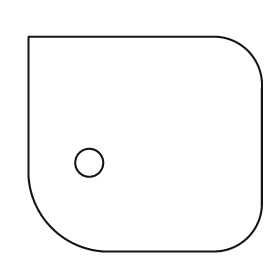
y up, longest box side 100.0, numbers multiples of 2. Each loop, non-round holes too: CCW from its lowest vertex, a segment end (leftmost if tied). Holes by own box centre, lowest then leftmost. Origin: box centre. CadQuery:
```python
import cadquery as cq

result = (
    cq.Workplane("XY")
    .moveTo(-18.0, -46.0)
    .lineTo(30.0, -46.0)
    .threePointArc((44.0, -40.0), (50.0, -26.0))
    .lineTo(50.0, 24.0)
    .threePointArc((44.0, 40.0), (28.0, 46.0))
    .lineTo(-50.0, 46.0)
    .lineTo(-50.0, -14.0)
    .threePointArc((-40.0, -36.0), (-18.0, -46.0))
    .close()
    .moveTo(-24.0, -8.0)
    .circle(6.0)
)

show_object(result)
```